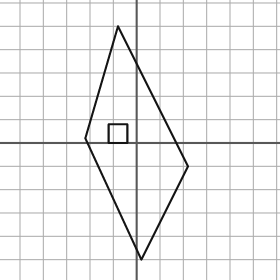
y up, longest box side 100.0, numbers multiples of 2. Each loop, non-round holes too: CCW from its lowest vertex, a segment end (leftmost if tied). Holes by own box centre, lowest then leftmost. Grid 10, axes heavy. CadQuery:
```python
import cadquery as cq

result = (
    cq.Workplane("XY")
    .moveTo(2.0, -50.0)
    .lineTo(22.0, -10.0)
    .lineTo(-8.0, 50.0)
    .lineTo(-22.0, 2.0)
    .close()
    .moveTo(-12.0, 0.0)
    .lineTo(-4.0, 0.0)
    .lineTo(-4.0, 8.0)
    .lineTo(-12.0, 8.0)
    .close()
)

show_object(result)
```